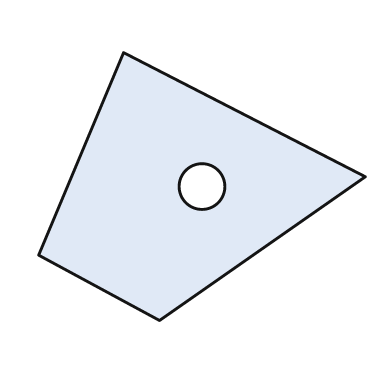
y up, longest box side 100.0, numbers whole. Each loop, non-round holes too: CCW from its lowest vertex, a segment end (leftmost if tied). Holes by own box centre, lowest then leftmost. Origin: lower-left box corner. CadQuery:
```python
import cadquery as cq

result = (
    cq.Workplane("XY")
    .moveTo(37.0, 0.0)
    .lineTo(100.0, 44.0)
    .lineTo(26.0, 82.0)
    .lineTo(0.0, 20.0)
    .close()
    .moveTo(50.0, 41.0)
    .circle(7.0)
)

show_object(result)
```